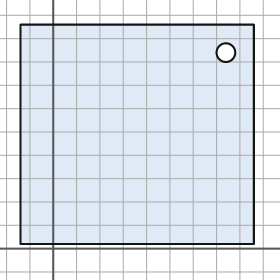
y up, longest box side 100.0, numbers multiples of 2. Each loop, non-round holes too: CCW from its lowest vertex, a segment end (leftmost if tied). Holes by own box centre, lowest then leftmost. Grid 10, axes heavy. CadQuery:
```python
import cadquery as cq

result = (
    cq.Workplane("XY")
    .moveTo(-14.0, 2.0)
    .lineTo(86.0, 2.0)
    .lineTo(86.0, 96.0)
    .lineTo(-14.0, 96.0)
    .close()
    .moveTo(74.0, 84.0)
    .circle(4.0)
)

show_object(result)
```